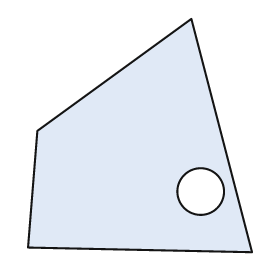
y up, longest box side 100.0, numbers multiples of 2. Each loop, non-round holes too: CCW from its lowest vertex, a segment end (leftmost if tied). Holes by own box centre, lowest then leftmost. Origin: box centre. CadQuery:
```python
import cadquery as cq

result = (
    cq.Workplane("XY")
    .moveTo(48.0, -50.0)
    .lineTo(22.0, 50.0)
    .lineTo(-44.0, 2.0)
    .lineTo(-48.0, -48.0)
    .close()
    .moveTo(26.0, -24.0)
    .circle(10.0)
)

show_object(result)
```